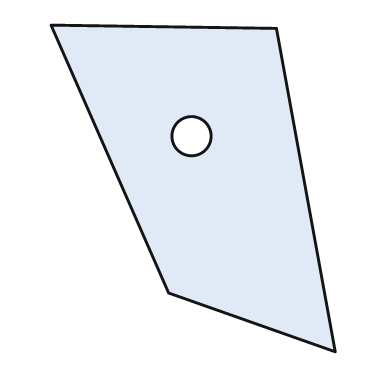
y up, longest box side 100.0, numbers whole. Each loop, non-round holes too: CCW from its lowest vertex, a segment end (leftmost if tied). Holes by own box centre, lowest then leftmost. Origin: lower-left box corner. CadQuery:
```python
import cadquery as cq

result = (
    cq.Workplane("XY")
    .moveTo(87.0, 0.0)
    .lineTo(69.0, 99.0)
    .lineTo(0.0, 100.0)
    .lineTo(36.0, 18.0)
    .close()
    .moveTo(43.0, 66.0)
    .circle(6.0)
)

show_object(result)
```